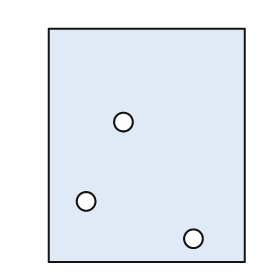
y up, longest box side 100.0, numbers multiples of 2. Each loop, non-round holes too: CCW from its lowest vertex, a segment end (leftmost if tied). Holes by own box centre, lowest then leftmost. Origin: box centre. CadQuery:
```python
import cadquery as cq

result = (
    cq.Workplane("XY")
    .moveTo(-42.0, -50.0)
    .lineTo(42.0, -50.0)
    .lineTo(42.0, 50.0)
    .lineTo(-42.0, 50.0)
    .close()
    .moveTo(20.0, -40.0)
    .circle(4.0)
    .moveTo(-26.0, -24.0)
    .circle(4.0)
    .moveTo(-10.0, 10.0)
    .circle(4.0)
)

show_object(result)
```